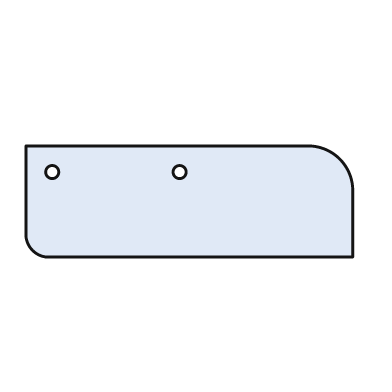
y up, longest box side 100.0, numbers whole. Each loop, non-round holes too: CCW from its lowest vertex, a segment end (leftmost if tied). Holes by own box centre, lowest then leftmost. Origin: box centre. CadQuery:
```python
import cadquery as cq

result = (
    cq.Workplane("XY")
    .moveTo(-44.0, -17.0)
    .lineTo(50.0, -17.0)
    .lineTo(50.0, 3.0)
    .threePointArc((46.0, 13.0), (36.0, 17.0))
    .lineTo(-50.0, 17.0)
    .lineTo(-50.0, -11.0)
    .threePointArc((-48.0, -15.0), (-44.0, -17.0))
    .close()
    .moveTo(-42.0, 9.0)
    .circle(2.0)
    .moveTo(-3.0, 9.0)
    .circle(2.0)
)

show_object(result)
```